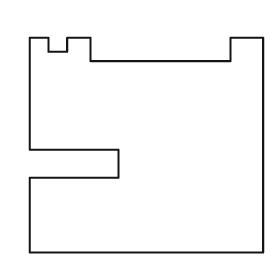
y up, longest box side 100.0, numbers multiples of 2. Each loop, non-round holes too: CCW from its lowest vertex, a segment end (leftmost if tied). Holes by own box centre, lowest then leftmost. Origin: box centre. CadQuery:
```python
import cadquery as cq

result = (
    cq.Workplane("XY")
    .moveTo(-50.0, -46.0)
    .lineTo(50.0, -46.0)
    .lineTo(50.0, 46.0)
    .lineTo(36.0, 46.0)
    .lineTo(36.0, 36.0)
    .lineTo(-24.0, 36.0)
    .lineTo(-24.0, 46.0)
    .lineTo(-34.0, 46.0)
    .lineTo(-34.0, 40.0)
    .lineTo(-42.0, 40.0)
    .lineTo(-42.0, 46.0)
    .lineTo(-50.0, 46.0)
    .lineTo(-50.0, -2.0)
    .lineTo(-12.0, -2.0)
    .lineTo(-12.0, -14.0)
    .lineTo(-50.0, -14.0)
    .close()
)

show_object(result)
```